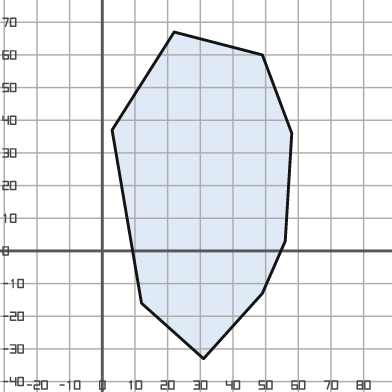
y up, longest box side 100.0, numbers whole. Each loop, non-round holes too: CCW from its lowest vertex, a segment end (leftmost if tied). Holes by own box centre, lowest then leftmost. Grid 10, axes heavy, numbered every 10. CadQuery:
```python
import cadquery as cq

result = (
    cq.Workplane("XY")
    .moveTo(31.0, -33.0)
    .lineTo(49.0, -13.0)
    .lineTo(56.0, 3.0)
    .lineTo(58.0, 36.0)
    .lineTo(49.0, 60.0)
    .lineTo(22.0, 67.0)
    .lineTo(3.0, 37.0)
    .lineTo(12.0, -16.0)
    .close()
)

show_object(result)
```